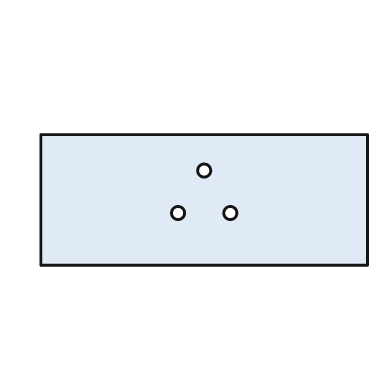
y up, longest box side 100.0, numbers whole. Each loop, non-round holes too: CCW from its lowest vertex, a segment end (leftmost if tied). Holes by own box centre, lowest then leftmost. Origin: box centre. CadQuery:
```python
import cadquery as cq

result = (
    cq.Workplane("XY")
    .moveTo(-50.0, -20.0)
    .lineTo(50.0, -20.0)
    .lineTo(50.0, 20.0)
    .lineTo(-50.0, 20.0)
    .close()
    .moveTo(-8.0, -4.0)
    .circle(2.0)
    .moveTo(8.0, -4.0)
    .circle(2.0)
    .moveTo(0.0, 9.0)
    .circle(2.0)
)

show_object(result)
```